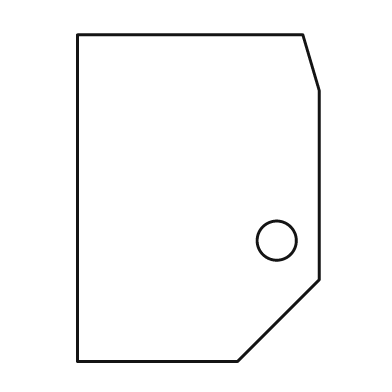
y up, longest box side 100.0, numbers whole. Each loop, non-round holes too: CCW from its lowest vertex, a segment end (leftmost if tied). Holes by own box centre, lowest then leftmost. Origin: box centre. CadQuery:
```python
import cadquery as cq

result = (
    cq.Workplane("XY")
    .moveTo(-37.0, -50.0)
    .lineTo(12.0, -50.0)
    .lineTo(37.0, -25.0)
    .lineTo(37.0, 33.0)
    .lineTo(32.0, 50.0)
    .lineTo(-37.0, 50.0)
    .close()
    .moveTo(24.0, -13.0)
    .circle(6.0)
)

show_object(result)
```